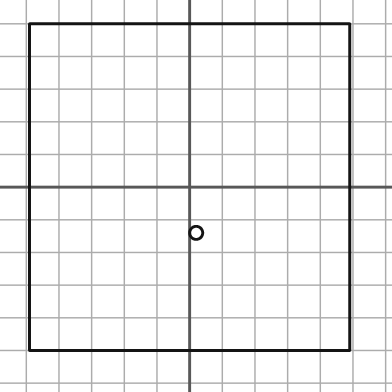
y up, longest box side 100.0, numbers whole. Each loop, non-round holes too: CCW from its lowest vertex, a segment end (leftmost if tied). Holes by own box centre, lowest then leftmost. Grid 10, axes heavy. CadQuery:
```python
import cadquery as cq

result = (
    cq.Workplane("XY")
    .moveTo(-49.0, -50.0)
    .lineTo(49.0, -50.0)
    .lineTo(49.0, 50.0)
    .lineTo(-49.0, 50.0)
    .close()
    .moveTo(2.0, -14.0)
    .circle(2.0)
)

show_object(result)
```